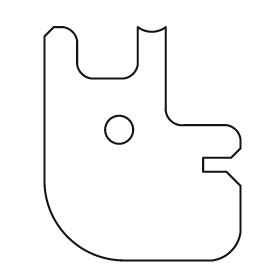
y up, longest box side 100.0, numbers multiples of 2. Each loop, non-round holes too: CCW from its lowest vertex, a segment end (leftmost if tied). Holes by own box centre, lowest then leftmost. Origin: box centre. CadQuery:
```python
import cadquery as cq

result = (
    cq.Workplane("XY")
    .moveTo(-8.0, -50.0)
    .lineTo(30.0, -50.0)
    .threePointArc((38.0, -46.0), (42.0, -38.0))
    .lineTo(42.0, -18.0)
    .lineTo(36.0, -12.0)
    .lineTo(26.0, -12.0)
    .lineTo(26.0, -6.0)
    .lineTo(38.0, -6.0)
    .lineTo(42.0, -2.0)
    .lineTo(42.0, 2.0)
    .threePointArc((40.0, 6.0), (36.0, 8.0))
    .lineTo(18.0, 8.0)
    .threePointArc((12.0, 10.0), (10.0, 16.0))
    .lineTo(10.0, 50.0)
    .threePointArc((4.0, 48.0), (-2.0, 50.0))
    .lineTo(-2.0, 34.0)
    .threePointArc((-4.0, 30.0), (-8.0, 28.0))
    .lineTo(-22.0, 28.0)
    .threePointArc((-26.0, 30.0), (-28.0, 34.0))
    .lineTo(-28.0, 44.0)
    .threePointArc((-30.0, 48.0), (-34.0, 50.0))
    .lineTo(-38.0, 50.0)
    .lineTo(-42.0, 46.0)
    .lineTo(-42.0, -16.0)
    .threePointArc((-32.0, -40.0), (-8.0, -50.0))
    .close()
    .moveTo(-10.0, 6.0)
    .circle(6.0)
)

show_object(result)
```